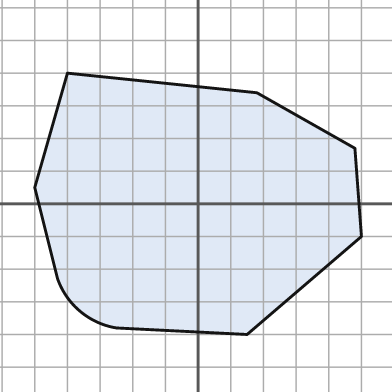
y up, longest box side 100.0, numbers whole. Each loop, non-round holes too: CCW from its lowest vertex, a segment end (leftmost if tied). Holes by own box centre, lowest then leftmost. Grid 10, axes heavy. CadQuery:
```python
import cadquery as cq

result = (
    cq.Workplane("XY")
    .moveTo(15.0, -40.0)
    .lineTo(50.0, -10.0)
    .lineTo(48.0, 17.0)
    .lineTo(18.0, 34.0)
    .lineTo(-40.0, 40.0)
    .lineTo(-50.0, 5.0)
    .lineTo(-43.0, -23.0)
    .threePointArc((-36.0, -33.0), (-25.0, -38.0))
    .close()
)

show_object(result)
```